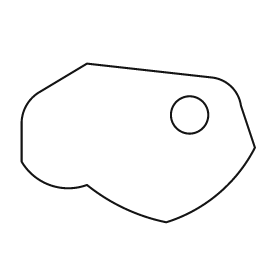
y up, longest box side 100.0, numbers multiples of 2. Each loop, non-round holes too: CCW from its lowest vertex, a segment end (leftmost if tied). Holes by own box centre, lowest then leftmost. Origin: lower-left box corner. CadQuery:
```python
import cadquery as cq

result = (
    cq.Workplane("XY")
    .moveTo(62.0, 0.0)
    .threePointArc((84.0, 12.0), (100.0, 32.0))
    .lineTo(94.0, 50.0)
    .threePointArc((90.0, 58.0), (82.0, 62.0))
    .lineTo(28.0, 68.0)
    .lineTo(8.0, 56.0)
    .threePointArc((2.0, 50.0), (0.0, 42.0))
    .lineTo(0.0, 26.0)
    .threePointArc((12.0, 16.0), (28.0, 16.0))
    .threePointArc((44.0, 6.0), (62.0, 0.0))
    .close()
    .moveTo(72.0, 46.0)
    .circle(8.0)
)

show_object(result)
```